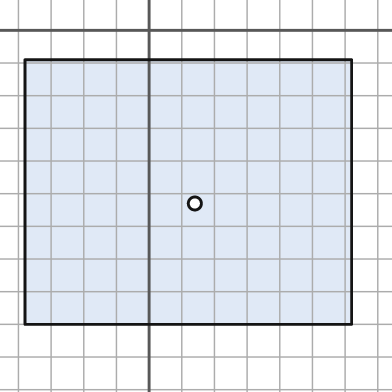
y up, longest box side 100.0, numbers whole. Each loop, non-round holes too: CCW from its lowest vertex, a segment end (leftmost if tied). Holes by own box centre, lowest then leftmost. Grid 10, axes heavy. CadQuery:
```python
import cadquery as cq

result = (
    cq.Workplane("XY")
    .moveTo(-38.0, -90.0)
    .lineTo(62.0, -90.0)
    .lineTo(62.0, -9.0)
    .lineTo(-38.0, -9.0)
    .close()
    .moveTo(14.0, -53.0)
    .circle(2.0)
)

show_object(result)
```